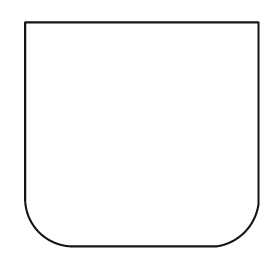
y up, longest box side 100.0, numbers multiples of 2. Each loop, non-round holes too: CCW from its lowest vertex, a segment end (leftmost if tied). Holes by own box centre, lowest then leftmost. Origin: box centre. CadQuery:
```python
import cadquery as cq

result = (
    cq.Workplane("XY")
    .moveTo(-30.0, -48.0)
    .lineTo(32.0, -48.0)
    .threePointArc((44.0, -42.0), (50.0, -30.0))
    .lineTo(50.0, 48.0)
    .lineTo(-50.0, 48.0)
    .lineTo(-50.0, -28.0)
    .threePointArc((-44.0, -42.0), (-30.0, -48.0))
    .close()
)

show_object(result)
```